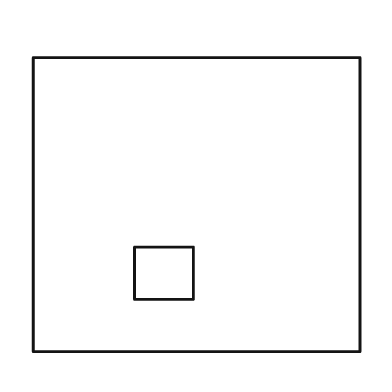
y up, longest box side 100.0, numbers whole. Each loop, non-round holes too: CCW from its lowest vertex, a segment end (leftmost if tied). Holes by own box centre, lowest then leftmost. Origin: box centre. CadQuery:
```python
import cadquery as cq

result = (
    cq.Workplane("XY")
    .moveTo(-50.0, -45.0)
    .lineTo(50.0, -45.0)
    .lineTo(50.0, 45.0)
    .lineTo(-50.0, 45.0)
    .close()
    .moveTo(-19.0, -29.0)
    .lineTo(-1.0, -29.0)
    .lineTo(-1.0, -13.0)
    .lineTo(-19.0, -13.0)
    .close()
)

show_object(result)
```